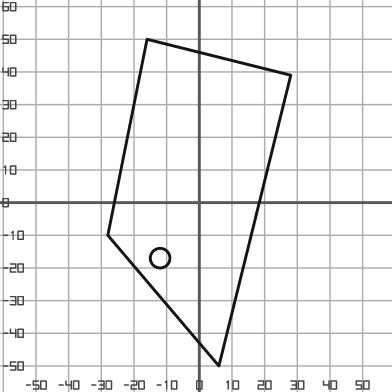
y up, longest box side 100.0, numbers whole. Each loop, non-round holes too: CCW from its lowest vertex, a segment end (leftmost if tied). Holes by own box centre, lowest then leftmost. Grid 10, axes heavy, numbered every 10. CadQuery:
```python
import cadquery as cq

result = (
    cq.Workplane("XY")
    .moveTo(6.0, -50.0)
    .lineTo(28.0, 39.0)
    .lineTo(-16.0, 50.0)
    .lineTo(-28.0, -10.0)
    .close()
    .moveTo(-12.0, -17.0)
    .circle(3.0)
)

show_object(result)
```